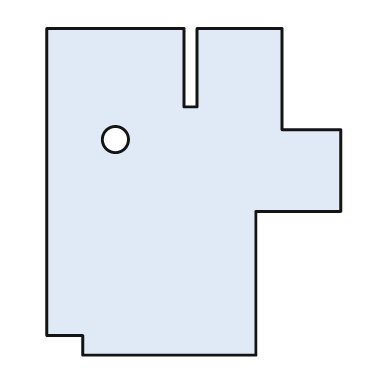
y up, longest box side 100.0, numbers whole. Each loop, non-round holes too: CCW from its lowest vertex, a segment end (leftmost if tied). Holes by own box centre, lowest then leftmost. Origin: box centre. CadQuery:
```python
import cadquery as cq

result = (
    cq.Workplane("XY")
    .moveTo(-34.0, -50.0)
    .lineTo(19.0, -50.0)
    .lineTo(19.0, -6.0)
    .lineTo(45.0, -6.0)
    .lineTo(45.0, 19.0)
    .lineTo(27.0, 19.0)
    .lineTo(27.0, 50.0)
    .lineTo(1.0, 50.0)
    .lineTo(1.0, 26.0)
    .lineTo(-3.0, 26.0)
    .lineTo(-3.0, 50.0)
    .lineTo(-45.0, 50.0)
    .lineTo(-45.0, -44.0)
    .lineTo(-34.0, -44.0)
    .close()
    .moveTo(-24.0, 16.0)
    .circle(4.0)
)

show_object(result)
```